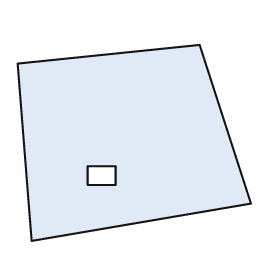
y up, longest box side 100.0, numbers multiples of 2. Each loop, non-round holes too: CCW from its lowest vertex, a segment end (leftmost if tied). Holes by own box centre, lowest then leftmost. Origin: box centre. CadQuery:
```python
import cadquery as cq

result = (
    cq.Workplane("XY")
    .moveTo(-44.0, -42.0)
    .lineTo(50.0, -26.0)
    .lineTo(28.0, 42.0)
    .lineTo(-50.0, 34.0)
    .close()
    .moveTo(-20.0, -18.0)
    .lineTo(-8.0, -18.0)
    .lineTo(-8.0, -10.0)
    .lineTo(-20.0, -10.0)
    .close()
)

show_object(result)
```